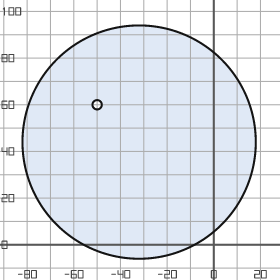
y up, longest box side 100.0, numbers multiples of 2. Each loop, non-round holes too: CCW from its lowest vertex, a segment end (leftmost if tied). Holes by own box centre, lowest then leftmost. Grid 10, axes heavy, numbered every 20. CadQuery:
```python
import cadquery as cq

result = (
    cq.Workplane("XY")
    .moveTo(-32.0, 44.0)
    .circle(50.0)
    .moveTo(-50.0, 60.0)
    .circle(2.0)
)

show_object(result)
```